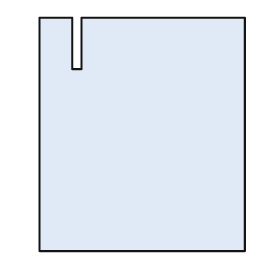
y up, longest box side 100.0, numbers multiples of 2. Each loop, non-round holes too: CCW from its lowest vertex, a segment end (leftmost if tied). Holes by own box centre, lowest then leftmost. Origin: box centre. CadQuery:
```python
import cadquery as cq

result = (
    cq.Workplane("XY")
    .moveTo(-44.0, -50.0)
    .lineTo(44.0, -50.0)
    .lineTo(44.0, 50.0)
    .lineTo(-26.0, 50.0)
    .lineTo(-26.0, 28.0)
    .lineTo(-30.0, 28.0)
    .lineTo(-30.0, 50.0)
    .lineTo(-44.0, 50.0)
    .close()
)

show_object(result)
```